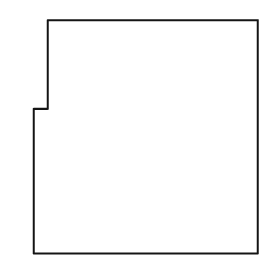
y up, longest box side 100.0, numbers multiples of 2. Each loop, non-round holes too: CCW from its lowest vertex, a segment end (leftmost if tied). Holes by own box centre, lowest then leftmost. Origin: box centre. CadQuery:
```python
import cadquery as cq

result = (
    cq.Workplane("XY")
    .moveTo(-48.0, -50.0)
    .lineTo(48.0, -50.0)
    .lineTo(48.0, 50.0)
    .lineTo(-42.0, 50.0)
    .lineTo(-42.0, 12.0)
    .lineTo(-48.0, 12.0)
    .close()
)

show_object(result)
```